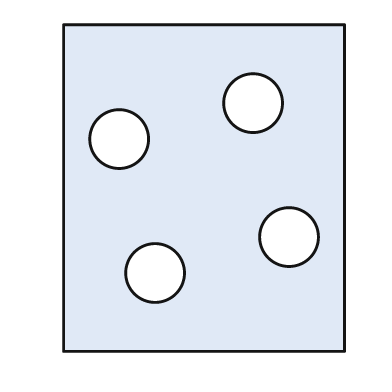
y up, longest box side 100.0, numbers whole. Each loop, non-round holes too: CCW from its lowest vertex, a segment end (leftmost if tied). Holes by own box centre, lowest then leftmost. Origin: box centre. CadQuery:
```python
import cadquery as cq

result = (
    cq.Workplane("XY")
    .moveTo(-43.0, -50.0)
    .lineTo(43.0, -50.0)
    .lineTo(43.0, 50.0)
    .lineTo(-43.0, 50.0)
    .close()
    .moveTo(-15.0, -26.0)
    .circle(9.0)
    .moveTo(26.0, -15.0)
    .circle(9.0)
    .moveTo(-26.0, 15.0)
    .circle(9.0)
    .moveTo(15.0, 26.0)
    .circle(9.0)
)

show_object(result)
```